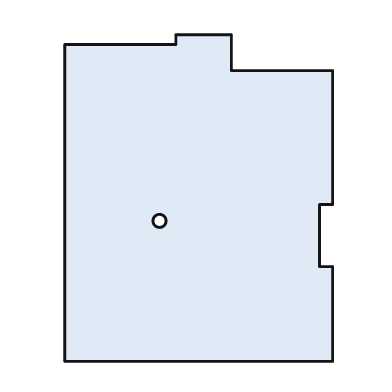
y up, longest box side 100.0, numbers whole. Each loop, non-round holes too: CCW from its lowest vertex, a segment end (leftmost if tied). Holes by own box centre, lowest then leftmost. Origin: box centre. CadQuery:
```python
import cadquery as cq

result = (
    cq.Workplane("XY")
    .moveTo(-41.0, -50.0)
    .lineTo(41.0, -50.0)
    .lineTo(41.0, -21.0)
    .lineTo(37.0, -21.0)
    .lineTo(37.0, -2.0)
    .lineTo(41.0, -2.0)
    .lineTo(41.0, 39.0)
    .lineTo(10.0, 39.0)
    .lineTo(10.0, 50.0)
    .lineTo(-7.0, 50.0)
    .lineTo(-7.0, 47.0)
    .lineTo(-41.0, 47.0)
    .close()
    .moveTo(-12.0, -7.0)
    .circle(2.0)
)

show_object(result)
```